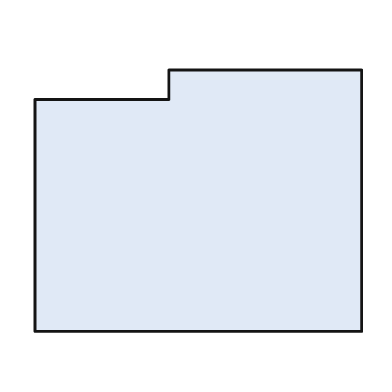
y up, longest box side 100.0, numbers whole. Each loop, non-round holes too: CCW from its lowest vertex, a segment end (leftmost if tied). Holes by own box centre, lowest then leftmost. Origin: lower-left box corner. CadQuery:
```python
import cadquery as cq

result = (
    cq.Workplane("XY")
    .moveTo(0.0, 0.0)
    .lineTo(100.0, 0.0)
    .lineTo(100.0, 80.0)
    .lineTo(41.0, 80.0)
    .lineTo(41.0, 71.0)
    .lineTo(0.0, 71.0)
    .close()
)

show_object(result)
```